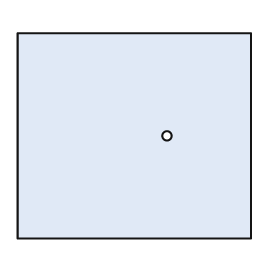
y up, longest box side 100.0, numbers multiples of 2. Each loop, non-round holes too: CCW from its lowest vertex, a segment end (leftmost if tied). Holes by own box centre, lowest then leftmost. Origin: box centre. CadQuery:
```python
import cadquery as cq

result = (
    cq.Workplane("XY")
    .moveTo(-50.0, -44.0)
    .lineTo(50.0, -44.0)
    .lineTo(50.0, 44.0)
    .lineTo(-50.0, 44.0)
    .close()
    .moveTo(14.0, 0.0)
    .circle(2.0)
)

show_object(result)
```